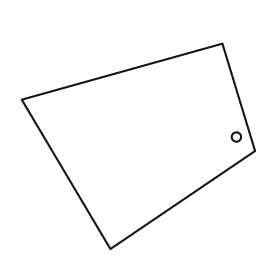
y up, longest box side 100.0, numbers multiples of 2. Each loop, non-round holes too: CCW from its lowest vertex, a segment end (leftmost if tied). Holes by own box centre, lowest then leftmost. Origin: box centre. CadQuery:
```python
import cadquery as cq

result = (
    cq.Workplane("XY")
    .moveTo(-12.0, -44.0)
    .lineTo(50.0, -2.0)
    .lineTo(36.0, 44.0)
    .lineTo(-50.0, 20.0)
    .close()
    .moveTo(42.0, 4.0)
    .circle(2.0)
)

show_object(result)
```